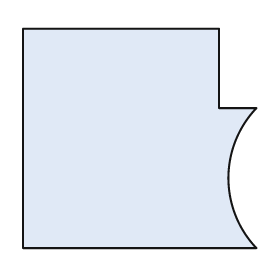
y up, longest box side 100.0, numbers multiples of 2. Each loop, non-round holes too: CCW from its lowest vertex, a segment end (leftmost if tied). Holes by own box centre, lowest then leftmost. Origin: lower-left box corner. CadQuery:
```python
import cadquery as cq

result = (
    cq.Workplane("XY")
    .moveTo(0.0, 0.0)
    .lineTo(100.0, 0.0)
    .threePointArc((88.0, 30.0), (100.0, 60.0))
    .lineTo(84.0, 60.0)
    .lineTo(84.0, 94.0)
    .lineTo(0.0, 94.0)
    .close()
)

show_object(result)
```